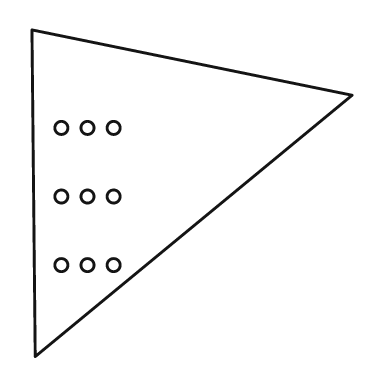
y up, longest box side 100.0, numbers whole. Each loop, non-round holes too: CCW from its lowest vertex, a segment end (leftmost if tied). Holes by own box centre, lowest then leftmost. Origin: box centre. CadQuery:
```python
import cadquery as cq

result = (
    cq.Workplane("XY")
    .moveTo(-48.0, -50.0)
    .lineTo(49.0, 30.0)
    .lineTo(-49.0, 50.0)
    .close()
    .moveTo(-40.0, -22.0)
    .circle(2.0)
    .moveTo(-32.0, -22.0)
    .circle(2.0)
    .moveTo(-24.0, -22.0)
    .circle(2.0)
    .moveTo(-40.0, -1.0)
    .circle(2.0)
    .moveTo(-32.0, -1.0)
    .circle(2.0)
    .moveTo(-24.0, -1.0)
    .circle(2.0)
    .moveTo(-40.0, 20.0)
    .circle(2.0)
    .moveTo(-32.0, 20.0)
    .circle(2.0)
    .moveTo(-24.0, 20.0)
    .circle(2.0)
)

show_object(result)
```